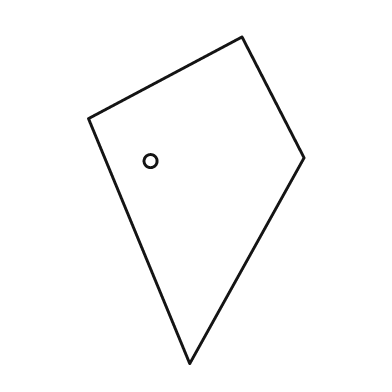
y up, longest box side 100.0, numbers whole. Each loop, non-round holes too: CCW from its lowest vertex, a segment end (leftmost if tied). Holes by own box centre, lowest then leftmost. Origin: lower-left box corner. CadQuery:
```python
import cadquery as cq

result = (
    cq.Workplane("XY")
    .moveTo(31.0, 0.0)
    .lineTo(66.0, 63.0)
    .lineTo(47.0, 100.0)
    .lineTo(0.0, 75.0)
    .close()
    .moveTo(19.0, 62.0)
    .circle(2.0)
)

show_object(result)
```